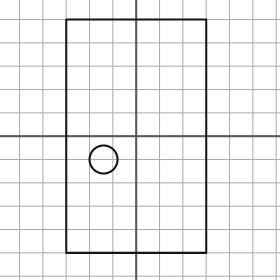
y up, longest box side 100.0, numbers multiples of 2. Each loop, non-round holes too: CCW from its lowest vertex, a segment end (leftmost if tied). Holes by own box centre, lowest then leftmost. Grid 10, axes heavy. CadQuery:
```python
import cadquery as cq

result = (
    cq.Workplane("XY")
    .moveTo(-30.0, -50.0)
    .lineTo(30.0, -50.0)
    .lineTo(30.0, 50.0)
    .lineTo(-30.0, 50.0)
    .close()
    .moveTo(-14.0, -10.0)
    .circle(6.0)
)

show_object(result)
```